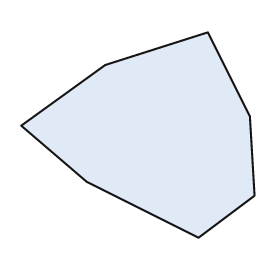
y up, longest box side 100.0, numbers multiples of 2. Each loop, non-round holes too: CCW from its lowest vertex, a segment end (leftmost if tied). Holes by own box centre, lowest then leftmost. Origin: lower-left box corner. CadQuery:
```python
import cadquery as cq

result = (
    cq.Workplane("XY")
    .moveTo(76.0, 0.0)
    .lineTo(100.0, 18.0)
    .lineTo(98.0, 52.0)
    .lineTo(80.0, 88.0)
    .lineTo(36.0, 74.0)
    .lineTo(0.0, 48.0)
    .lineTo(28.0, 24.0)
    .close()
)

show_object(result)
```